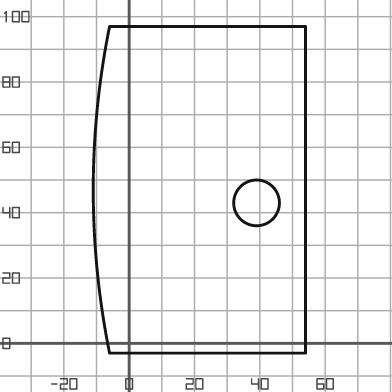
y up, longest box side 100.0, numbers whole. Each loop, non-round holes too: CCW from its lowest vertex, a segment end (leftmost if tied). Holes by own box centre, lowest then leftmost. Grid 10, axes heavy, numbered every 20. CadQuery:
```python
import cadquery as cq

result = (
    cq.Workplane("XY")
    .moveTo(-6.0, -3.0)
    .lineTo(54.0, -3.0)
    .lineTo(54.0, 97.0)
    .lineTo(-6.0, 97.0)
    .threePointArc((-11.0, 47.0), (-6.0, -3.0))
    .close()
    .moveTo(39.0, 43.0)
    .circle(7.0)
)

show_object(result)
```